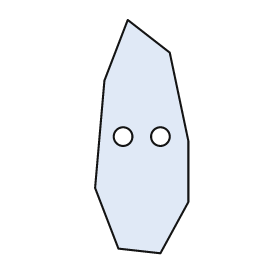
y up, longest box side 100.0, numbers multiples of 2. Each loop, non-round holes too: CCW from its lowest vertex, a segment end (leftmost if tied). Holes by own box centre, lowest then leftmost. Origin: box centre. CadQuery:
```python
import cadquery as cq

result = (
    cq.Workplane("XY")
    .moveTo(8.0, -50.0)
    .lineTo(20.0, -28.0)
    .lineTo(20.0, -2.0)
    .lineTo(12.0, 36.0)
    .lineTo(-6.0, 50.0)
    .lineTo(-16.0, 24.0)
    .lineTo(-20.0, -22.0)
    .lineTo(-10.0, -48.0)
    .close()
    .moveTo(-8.0, 0.0)
    .circle(4.0)
    .moveTo(8.0, 0.0)
    .circle(4.0)
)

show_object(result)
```